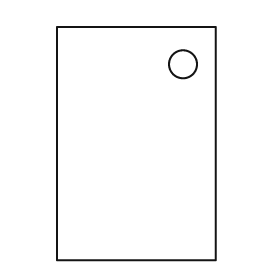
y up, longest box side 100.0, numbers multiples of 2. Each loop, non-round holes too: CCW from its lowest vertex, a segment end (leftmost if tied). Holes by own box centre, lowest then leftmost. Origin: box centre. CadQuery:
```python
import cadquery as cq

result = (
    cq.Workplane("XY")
    .moveTo(-34.0, -50.0)
    .lineTo(34.0, -50.0)
    .lineTo(34.0, 50.0)
    .lineTo(-34.0, 50.0)
    .close()
    .moveTo(20.0, 34.0)
    .circle(6.0)
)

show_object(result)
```